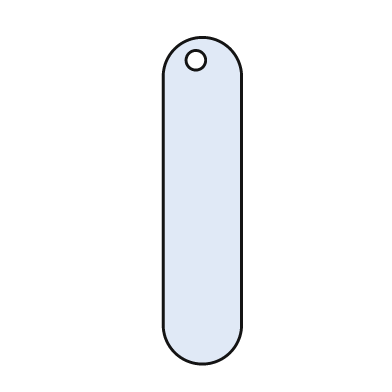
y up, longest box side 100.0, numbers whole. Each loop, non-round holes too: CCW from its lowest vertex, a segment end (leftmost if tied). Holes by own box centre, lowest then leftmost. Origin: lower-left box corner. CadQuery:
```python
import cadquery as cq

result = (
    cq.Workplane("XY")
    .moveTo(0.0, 12.0)
    .threePointArc((12.0, 0.0), (24.0, 12.0))
    .lineTo(24.0, 88.0)
    .threePointArc((12.0, 100.0), (0.0, 88.0))
    .close()
    .moveTo(10.0, 93.0)
    .circle(3.0)
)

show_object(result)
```